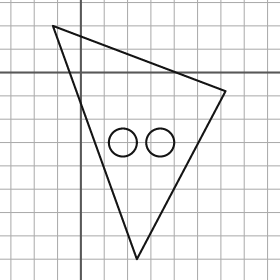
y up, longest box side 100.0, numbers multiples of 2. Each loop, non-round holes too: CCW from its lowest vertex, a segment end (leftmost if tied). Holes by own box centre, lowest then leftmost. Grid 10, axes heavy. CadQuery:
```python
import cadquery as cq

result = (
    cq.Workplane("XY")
    .moveTo(24.0, -80.0)
    .lineTo(62.0, -8.0)
    .lineTo(-12.0, 20.0)
    .close()
    .moveTo(18.0, -30.0)
    .circle(6.0)
    .moveTo(34.0, -30.0)
    .circle(6.0)
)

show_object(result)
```